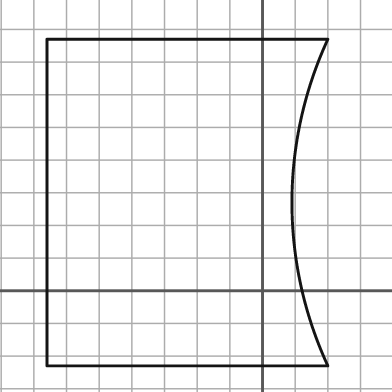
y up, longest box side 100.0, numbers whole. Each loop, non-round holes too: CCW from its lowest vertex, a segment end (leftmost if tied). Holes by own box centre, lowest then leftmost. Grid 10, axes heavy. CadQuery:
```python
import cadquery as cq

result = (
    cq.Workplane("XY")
    .moveTo(-66.0, -23.0)
    .lineTo(20.0, -23.0)
    .threePointArc((9.0, 27.0), (20.0, 77.0))
    .lineTo(-66.0, 77.0)
    .close()
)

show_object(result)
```